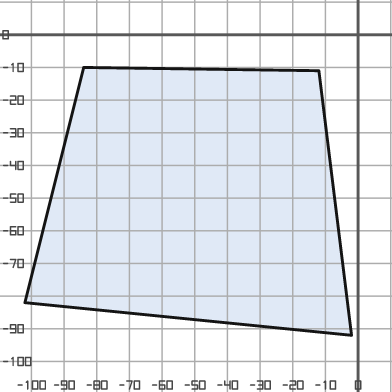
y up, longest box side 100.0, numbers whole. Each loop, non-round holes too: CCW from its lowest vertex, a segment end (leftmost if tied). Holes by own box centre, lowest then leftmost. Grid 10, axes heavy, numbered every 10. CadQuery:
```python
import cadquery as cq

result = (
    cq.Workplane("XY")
    .moveTo(-2.0, -92.0)
    .lineTo(-12.0, -11.0)
    .lineTo(-84.0, -10.0)
    .lineTo(-102.0, -82.0)
    .close()
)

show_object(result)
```